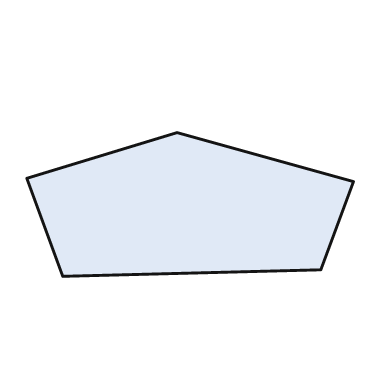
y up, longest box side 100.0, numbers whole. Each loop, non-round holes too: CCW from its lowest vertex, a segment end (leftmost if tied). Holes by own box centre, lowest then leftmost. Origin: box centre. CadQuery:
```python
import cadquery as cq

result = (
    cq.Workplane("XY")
    .moveTo(-39.0, -22.0)
    .lineTo(40.0, -20.0)
    .lineTo(50.0, 7.0)
    .lineTo(-4.0, 22.0)
    .lineTo(-50.0, 8.0)
    .close()
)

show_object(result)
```